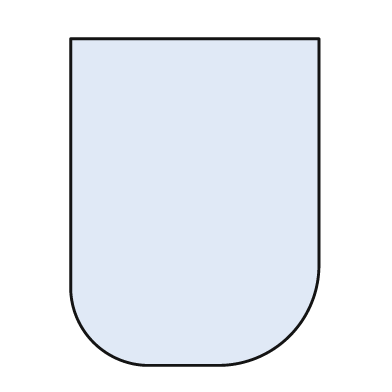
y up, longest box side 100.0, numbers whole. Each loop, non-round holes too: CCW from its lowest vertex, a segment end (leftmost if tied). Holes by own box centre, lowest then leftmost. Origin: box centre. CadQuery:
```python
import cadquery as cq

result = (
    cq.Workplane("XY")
    .moveTo(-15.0, -50.0)
    .lineTo(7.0, -50.0)
    .threePointArc((29.0, -41.0), (38.0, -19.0))
    .lineTo(38.0, 50.0)
    .lineTo(-38.0, 50.0)
    .lineTo(-38.0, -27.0)
    .threePointArc((-31.0, -43.0), (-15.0, -50.0))
    .close()
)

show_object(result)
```